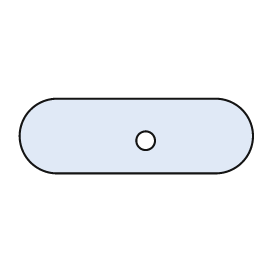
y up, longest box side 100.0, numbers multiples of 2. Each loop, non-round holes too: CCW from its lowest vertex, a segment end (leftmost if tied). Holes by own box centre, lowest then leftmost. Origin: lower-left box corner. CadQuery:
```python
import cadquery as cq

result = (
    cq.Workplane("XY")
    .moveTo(16.0, 0.0)
    .lineTo(84.0, 0.0)
    .threePointArc((100.0, 16.0), (84.0, 32.0))
    .lineTo(16.0, 32.0)
    .threePointArc((0.0, 16.0), (16.0, 0.0))
    .close()
    .moveTo(54.0, 14.0)
    .circle(4.0)
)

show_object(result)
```